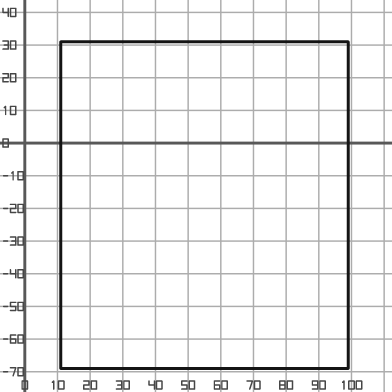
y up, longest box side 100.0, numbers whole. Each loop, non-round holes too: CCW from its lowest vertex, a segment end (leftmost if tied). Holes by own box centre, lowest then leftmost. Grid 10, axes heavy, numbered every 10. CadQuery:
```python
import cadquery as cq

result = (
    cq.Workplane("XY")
    .moveTo(11.0, -69.0)
    .lineTo(99.0, -69.0)
    .lineTo(99.0, 31.0)
    .lineTo(11.0, 31.0)
    .close()
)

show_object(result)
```